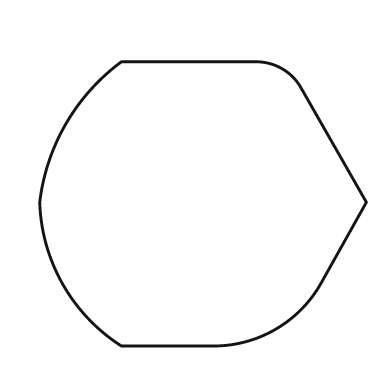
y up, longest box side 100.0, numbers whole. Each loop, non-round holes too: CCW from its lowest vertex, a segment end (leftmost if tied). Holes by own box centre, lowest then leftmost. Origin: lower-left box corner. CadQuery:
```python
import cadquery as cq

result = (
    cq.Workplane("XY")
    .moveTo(25.0, 0.0)
    .lineTo(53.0, 0.0)
    .threePointArc((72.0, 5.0), (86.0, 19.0))
    .lineTo(100.0, 44.0)
    .lineTo(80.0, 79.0)
    .threePointArc((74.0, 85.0), (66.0, 87.0))
    .lineTo(25.0, 87.0)
    .threePointArc((8.0, 68.0), (0.0, 44.0))
    .threePointArc((7.0, 19.0), (25.0, 0.0))
    .close()
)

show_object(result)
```